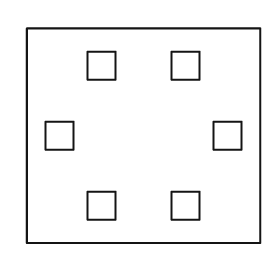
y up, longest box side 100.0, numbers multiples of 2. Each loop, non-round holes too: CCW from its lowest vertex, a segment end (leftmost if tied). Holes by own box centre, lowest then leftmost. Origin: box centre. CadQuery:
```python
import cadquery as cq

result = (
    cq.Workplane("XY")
    .moveTo(-50.0, -46.0)
    .lineTo(50.0, -46.0)
    .lineTo(50.0, 46.0)
    .lineTo(-50.0, 46.0)
    .close()
    .moveTo(-24.0, -36.0)
    .lineTo(-12.0, -36.0)
    .lineTo(-12.0, -24.0)
    .lineTo(-24.0, -24.0)
    .close()
    .moveTo(12.0, -36.0)
    .lineTo(24.0, -36.0)
    .lineTo(24.0, -24.0)
    .lineTo(12.0, -24.0)
    .close()
    .moveTo(-42.0, -6.0)
    .lineTo(-30.0, -6.0)
    .lineTo(-30.0, 6.0)
    .lineTo(-42.0, 6.0)
    .close()
    .moveTo(30.0, -6.0)
    .lineTo(42.0, -6.0)
    .lineTo(42.0, 6.0)
    .lineTo(30.0, 6.0)
    .close()
    .moveTo(-24.0, 24.0)
    .lineTo(-12.0, 24.0)
    .lineTo(-12.0, 36.0)
    .lineTo(-24.0, 36.0)
    .close()
    .moveTo(12.0, 24.0)
    .lineTo(24.0, 24.0)
    .lineTo(24.0, 36.0)
    .lineTo(12.0, 36.0)
    .close()
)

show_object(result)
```